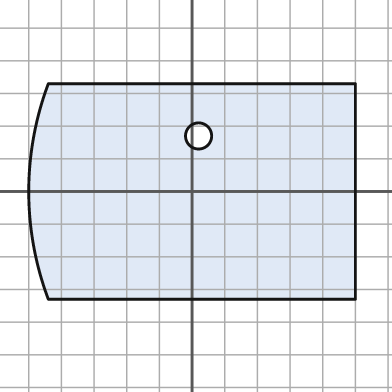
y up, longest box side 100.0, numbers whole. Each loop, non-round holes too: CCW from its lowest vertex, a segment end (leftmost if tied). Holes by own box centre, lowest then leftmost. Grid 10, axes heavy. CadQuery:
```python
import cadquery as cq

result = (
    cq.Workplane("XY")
    .moveTo(-44.0, -33.0)
    .lineTo(50.0, -33.0)
    .lineTo(50.0, 33.0)
    .lineTo(-44.0, 33.0)
    .threePointArc((-50.0, 0.0), (-44.0, -33.0))
    .close()
    .moveTo(2.0, 17.0)
    .circle(4.0)
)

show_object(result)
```